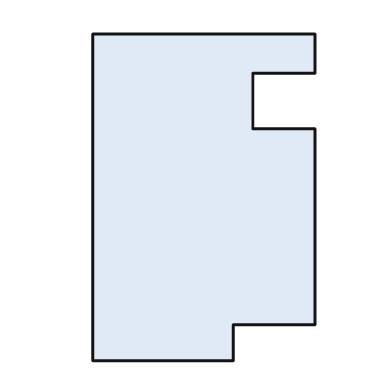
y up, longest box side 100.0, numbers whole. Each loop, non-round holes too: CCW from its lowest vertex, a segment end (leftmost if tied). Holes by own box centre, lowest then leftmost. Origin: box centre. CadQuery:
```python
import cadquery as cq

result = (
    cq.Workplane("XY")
    .moveTo(-34.0, -50.0)
    .lineTo(9.0, -50.0)
    .lineTo(9.0, -39.0)
    .lineTo(34.0, -39.0)
    .lineTo(34.0, 21.0)
    .lineTo(15.0, 21.0)
    .lineTo(15.0, 38.0)
    .lineTo(34.0, 38.0)
    .lineTo(34.0, 50.0)
    .lineTo(-34.0, 50.0)
    .close()
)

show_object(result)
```